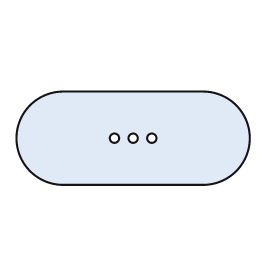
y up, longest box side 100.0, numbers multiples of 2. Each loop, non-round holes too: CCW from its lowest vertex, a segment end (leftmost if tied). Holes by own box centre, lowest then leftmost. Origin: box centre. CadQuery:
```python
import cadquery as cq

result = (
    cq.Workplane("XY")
    .moveTo(-30.0, -20.0)
    .lineTo(30.0, -20.0)
    .threePointArc((50.0, 0.0), (30.0, 20.0))
    .lineTo(-30.0, 20.0)
    .threePointArc((-50.0, 0.0), (-30.0, -20.0))
    .close()
    .moveTo(-8.0, 0.0)
    .circle(2.0)
    .moveTo(0.0, 0.0)
    .circle(2.0)
    .moveTo(8.0, 0.0)
    .circle(2.0)
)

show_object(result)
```